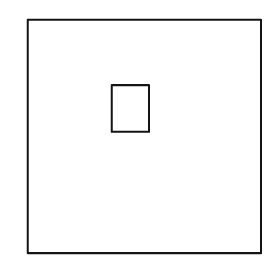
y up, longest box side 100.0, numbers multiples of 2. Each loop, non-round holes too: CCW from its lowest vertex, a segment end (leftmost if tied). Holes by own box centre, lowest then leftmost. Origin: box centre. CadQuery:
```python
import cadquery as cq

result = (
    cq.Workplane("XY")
    .moveTo(-50.0, -50.0)
    .lineTo(50.0, -50.0)
    .lineTo(50.0, 50.0)
    .lineTo(-50.0, 50.0)
    .close()
    .moveTo(-14.0, 2.0)
    .lineTo(2.0, 2.0)
    .lineTo(2.0, 22.0)
    .lineTo(-14.0, 22.0)
    .close()
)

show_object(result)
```